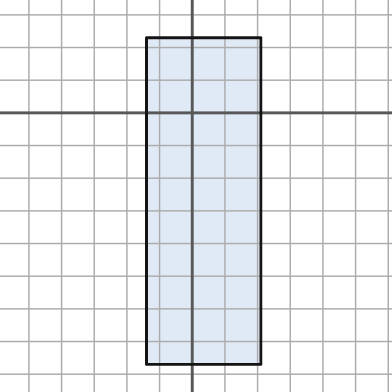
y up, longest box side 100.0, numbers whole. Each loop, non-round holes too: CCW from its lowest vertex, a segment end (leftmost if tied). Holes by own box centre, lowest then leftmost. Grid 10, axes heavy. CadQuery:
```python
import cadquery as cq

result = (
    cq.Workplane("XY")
    .moveTo(-14.0, -77.0)
    .lineTo(21.0, -77.0)
    .lineTo(21.0, 23.0)
    .lineTo(-14.0, 23.0)
    .close()
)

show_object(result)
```